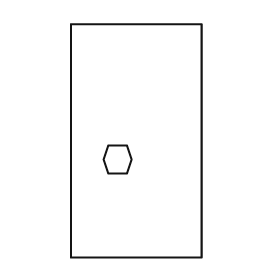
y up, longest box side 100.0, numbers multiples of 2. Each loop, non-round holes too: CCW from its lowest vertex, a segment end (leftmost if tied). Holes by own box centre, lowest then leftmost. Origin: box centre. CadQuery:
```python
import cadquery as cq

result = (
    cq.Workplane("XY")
    .moveTo(-28.0, -50.0)
    .lineTo(28.0, -50.0)
    .lineTo(28.0, 50.0)
    .lineTo(-28.0, 50.0)
    .close()
    .moveTo(-12.0, -14.0)
    .lineTo(-4.0, -14.0)
    .lineTo(-2.0, -8.0)
    .lineTo(-4.0, -2.0)
    .lineTo(-12.0, -2.0)
    .lineTo(-14.0, -8.0)
    .close()
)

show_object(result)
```